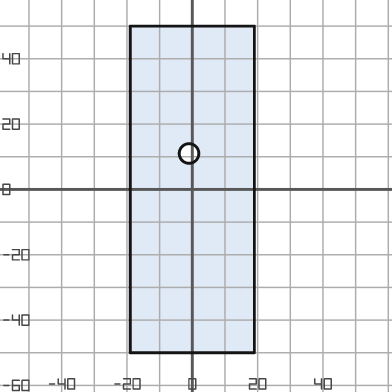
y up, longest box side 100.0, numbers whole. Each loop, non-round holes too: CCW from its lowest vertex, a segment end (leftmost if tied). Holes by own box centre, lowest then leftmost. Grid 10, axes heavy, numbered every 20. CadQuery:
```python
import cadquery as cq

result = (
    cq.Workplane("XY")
    .moveTo(-19.0, -50.0)
    .lineTo(19.0, -50.0)
    .lineTo(19.0, 50.0)
    .lineTo(-19.0, 50.0)
    .close()
    .moveTo(-1.0, 11.0)
    .circle(3.0)
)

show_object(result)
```